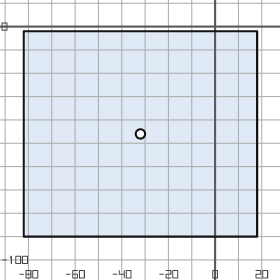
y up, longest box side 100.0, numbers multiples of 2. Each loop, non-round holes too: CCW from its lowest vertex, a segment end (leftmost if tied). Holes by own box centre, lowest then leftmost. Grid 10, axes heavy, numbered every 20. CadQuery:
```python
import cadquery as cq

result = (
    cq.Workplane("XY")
    .moveTo(-82.0, -90.0)
    .lineTo(18.0, -90.0)
    .lineTo(18.0, -2.0)
    .lineTo(-82.0, -2.0)
    .close()
    .moveTo(-32.0, -46.0)
    .circle(2.0)
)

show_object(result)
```